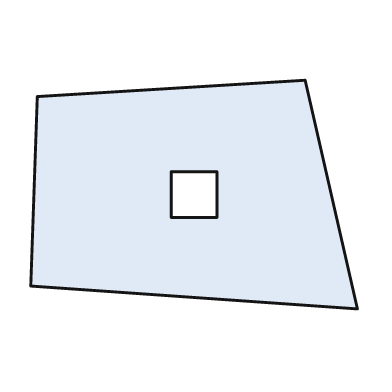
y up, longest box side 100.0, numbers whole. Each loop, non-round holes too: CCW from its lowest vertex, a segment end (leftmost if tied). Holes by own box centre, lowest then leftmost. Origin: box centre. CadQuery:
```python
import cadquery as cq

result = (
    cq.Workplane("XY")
    .moveTo(50.0, -35.0)
    .lineTo(34.0, 35.0)
    .lineTo(-48.0, 30.0)
    .lineTo(-50.0, -28.0)
    .close()
    .moveTo(-7.0, -7.0)
    .lineTo(7.0, -7.0)
    .lineTo(7.0, 7.0)
    .lineTo(-7.0, 7.0)
    .close()
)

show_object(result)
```